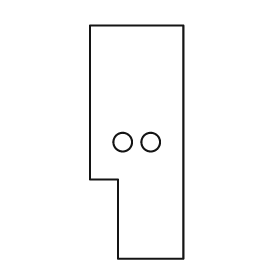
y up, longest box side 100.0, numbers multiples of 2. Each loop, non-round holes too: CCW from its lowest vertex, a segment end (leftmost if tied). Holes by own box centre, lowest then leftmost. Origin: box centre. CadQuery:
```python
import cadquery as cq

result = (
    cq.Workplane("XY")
    .moveTo(-8.0, -50.0)
    .lineTo(20.0, -50.0)
    .lineTo(20.0, 50.0)
    .lineTo(-20.0, 50.0)
    .lineTo(-20.0, -16.0)
    .lineTo(-8.0, -16.0)
    .close()
    .moveTo(-6.0, 0.0)
    .circle(4.0)
    .moveTo(6.0, 0.0)
    .circle(4.0)
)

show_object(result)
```